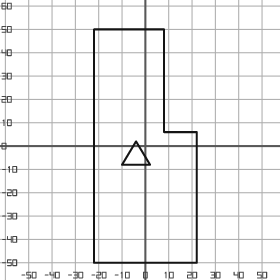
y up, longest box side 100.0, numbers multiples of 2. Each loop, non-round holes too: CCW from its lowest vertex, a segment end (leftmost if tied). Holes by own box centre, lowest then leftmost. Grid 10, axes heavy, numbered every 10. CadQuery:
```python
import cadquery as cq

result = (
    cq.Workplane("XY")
    .moveTo(-22.0, -50.0)
    .lineTo(22.0, -50.0)
    .lineTo(22.0, 6.0)
    .lineTo(8.0, 6.0)
    .lineTo(8.0, 50.0)
    .lineTo(-22.0, 50.0)
    .close()
    .moveTo(-10.0, -8.0)
    .lineTo(2.0, -8.0)
    .lineTo(-4.0, 2.0)
    .close()
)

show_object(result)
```